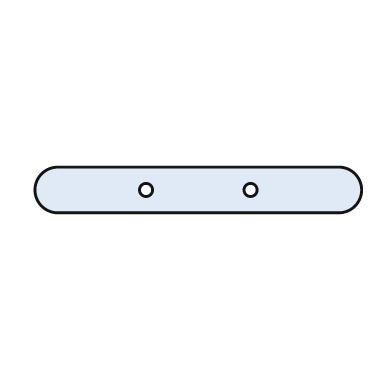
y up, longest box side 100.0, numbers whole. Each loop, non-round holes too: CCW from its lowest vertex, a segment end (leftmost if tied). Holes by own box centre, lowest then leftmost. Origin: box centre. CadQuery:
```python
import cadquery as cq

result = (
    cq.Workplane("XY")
    .moveTo(-43.0, -7.0)
    .lineTo(43.0, -7.0)
    .threePointArc((50.0, 0.0), (43.0, 7.0))
    .lineTo(-43.0, 7.0)
    .threePointArc((-50.0, 0.0), (-43.0, -7.0))
    .close()
    .moveTo(-16.0, 0.0)
    .circle(2.0)
    .moveTo(16.0, 0.0)
    .circle(2.0)
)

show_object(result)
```